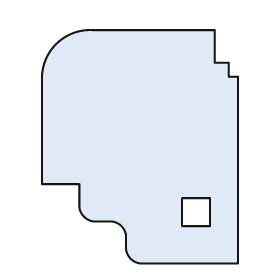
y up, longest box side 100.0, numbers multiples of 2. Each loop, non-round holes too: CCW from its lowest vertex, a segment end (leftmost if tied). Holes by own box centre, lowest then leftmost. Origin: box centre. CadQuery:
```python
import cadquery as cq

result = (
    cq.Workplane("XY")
    .moveTo(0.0, -50.0)
    .lineTo(42.0, -50.0)
    .lineTo(42.0, 30.0)
    .lineTo(38.0, 30.0)
    .lineTo(38.0, 36.0)
    .lineTo(32.0, 36.0)
    .lineTo(32.0, 50.0)
    .lineTo(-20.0, 50.0)
    .threePointArc((-36.0, 44.0), (-42.0, 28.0))
    .lineTo(-42.0, -16.0)
    .lineTo(-26.0, -16.0)
    .lineTo(-26.0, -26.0)
    .threePointArc((-24.0, -30.0), (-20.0, -32.0))
    .lineTo(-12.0, -32.0)
    .threePointArc((-8.0, -34.0), (-6.0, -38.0))
    .lineTo(-6.0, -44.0)
    .threePointArc((-4.0, -48.0), (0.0, -50.0))
    .close()
    .moveTo(18.0, -34.0)
    .lineTo(30.0, -34.0)
    .lineTo(30.0, -22.0)
    .lineTo(18.0, -22.0)
    .close()
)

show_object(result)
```